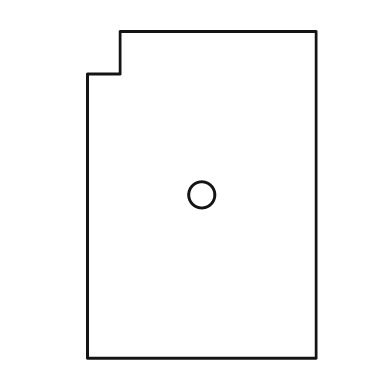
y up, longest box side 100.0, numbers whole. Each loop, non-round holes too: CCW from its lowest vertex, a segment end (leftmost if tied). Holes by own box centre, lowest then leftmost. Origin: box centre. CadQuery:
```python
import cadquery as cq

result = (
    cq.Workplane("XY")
    .moveTo(-35.0, -50.0)
    .lineTo(35.0, -50.0)
    .lineTo(35.0, 50.0)
    .lineTo(-25.0, 50.0)
    .lineTo(-25.0, 37.0)
    .lineTo(-35.0, 37.0)
    .close()
    .moveTo(0.0, 0.0)
    .circle(4.0)
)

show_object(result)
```